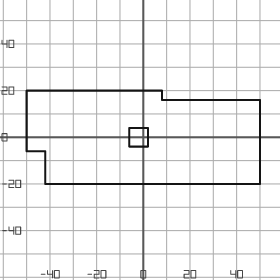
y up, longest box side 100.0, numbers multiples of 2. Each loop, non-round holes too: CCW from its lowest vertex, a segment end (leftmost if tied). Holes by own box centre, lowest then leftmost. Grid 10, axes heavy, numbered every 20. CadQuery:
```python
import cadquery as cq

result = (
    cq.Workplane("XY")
    .moveTo(-42.0, -20.0)
    .lineTo(50.0, -20.0)
    .lineTo(50.0, 16.0)
    .lineTo(8.0, 16.0)
    .lineTo(8.0, 20.0)
    .lineTo(-50.0, 20.0)
    .lineTo(-50.0, -6.0)
    .lineTo(-42.0, -6.0)
    .close()
    .moveTo(-6.0, -4.0)
    .lineTo(2.0, -4.0)
    .lineTo(2.0, 4.0)
    .lineTo(-6.0, 4.0)
    .close()
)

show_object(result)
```